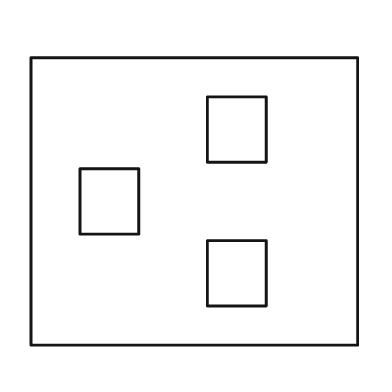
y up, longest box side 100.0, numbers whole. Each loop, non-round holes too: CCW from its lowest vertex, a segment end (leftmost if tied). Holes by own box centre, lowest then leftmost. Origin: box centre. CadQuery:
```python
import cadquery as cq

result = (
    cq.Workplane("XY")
    .moveTo(-50.0, -44.0)
    .lineTo(50.0, -44.0)
    .lineTo(50.0, 44.0)
    .lineTo(-50.0, 44.0)
    .close()
    .moveTo(4.0, -32.0)
    .lineTo(22.0, -32.0)
    .lineTo(22.0, -12.0)
    .lineTo(4.0, -12.0)
    .close()
    .moveTo(-35.0, -10.0)
    .lineTo(-17.0, -10.0)
    .lineTo(-17.0, 10.0)
    .lineTo(-35.0, 10.0)
    .close()
    .moveTo(4.0, 12.0)
    .lineTo(22.0, 12.0)
    .lineTo(22.0, 32.0)
    .lineTo(4.0, 32.0)
    .close()
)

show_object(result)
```